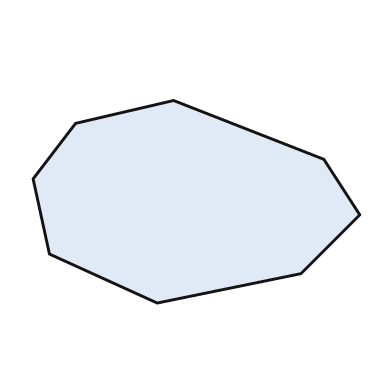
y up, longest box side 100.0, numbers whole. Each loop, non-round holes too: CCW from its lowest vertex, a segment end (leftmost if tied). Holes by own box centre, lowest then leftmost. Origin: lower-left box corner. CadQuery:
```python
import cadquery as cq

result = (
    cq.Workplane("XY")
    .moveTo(38.0, 0.0)
    .lineTo(82.0, 9.0)
    .lineTo(100.0, 27.0)
    .lineTo(89.0, 44.0)
    .lineTo(43.0, 62.0)
    .lineTo(13.0, 55.0)
    .lineTo(0.0, 38.0)
    .lineTo(5.0, 15.0)
    .close()
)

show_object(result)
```